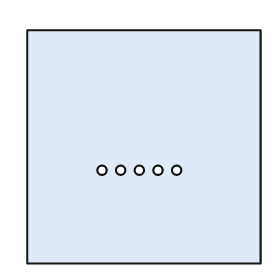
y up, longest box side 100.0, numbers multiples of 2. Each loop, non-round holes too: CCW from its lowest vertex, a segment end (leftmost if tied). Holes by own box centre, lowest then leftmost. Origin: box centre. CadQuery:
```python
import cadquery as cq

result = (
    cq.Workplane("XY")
    .moveTo(-50.0, -50.0)
    .lineTo(50.0, -50.0)
    .lineTo(50.0, 50.0)
    .lineTo(-50.0, 50.0)
    .close()
    .moveTo(-18.0, -10.0)
    .circle(2.0)
    .moveTo(-10.0, -10.0)
    .circle(2.0)
    .moveTo(-2.0, -10.0)
    .circle(2.0)
    .moveTo(6.0, -10.0)
    .circle(2.0)
    .moveTo(14.0, -10.0)
    .circle(2.0)
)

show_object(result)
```